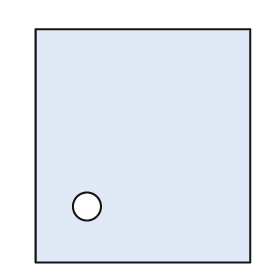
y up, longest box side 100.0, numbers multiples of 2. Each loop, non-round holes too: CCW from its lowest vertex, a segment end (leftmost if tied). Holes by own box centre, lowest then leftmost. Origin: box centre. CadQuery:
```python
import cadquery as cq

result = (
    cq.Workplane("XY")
    .moveTo(-46.0, -50.0)
    .lineTo(46.0, -50.0)
    .lineTo(46.0, 50.0)
    .lineTo(-46.0, 50.0)
    .close()
    .moveTo(-24.0, -26.0)
    .circle(6.0)
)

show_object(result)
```